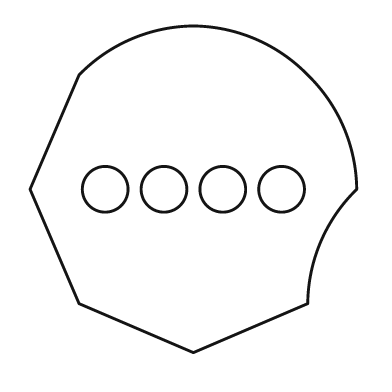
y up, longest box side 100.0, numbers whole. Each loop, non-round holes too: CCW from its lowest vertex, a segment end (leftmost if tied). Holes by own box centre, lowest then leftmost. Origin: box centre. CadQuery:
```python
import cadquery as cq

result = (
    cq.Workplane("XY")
    .moveTo(0.0, -50.0)
    .lineTo(35.0, -35.0)
    .threePointArc((39.0, -16.0), (50.0, 0.0))
    .threePointArc((46.0, 19.0), (35.0, 35.0))
    .threePointArc((19.0, 46.0), (0.0, 50.0))
    .threePointArc((-19.0, 46.0), (-35.0, 35.0))
    .lineTo(-50.0, 0.0)
    .lineTo(-35.0, -35.0)
    .close()
    .moveTo(-27.0, 0.0)
    .circle(7.0)
    .moveTo(-9.0, 0.0)
    .circle(7.0)
    .moveTo(9.0, 0.0)
    .circle(7.0)
    .moveTo(27.0, 0.0)
    .circle(7.0)
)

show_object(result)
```